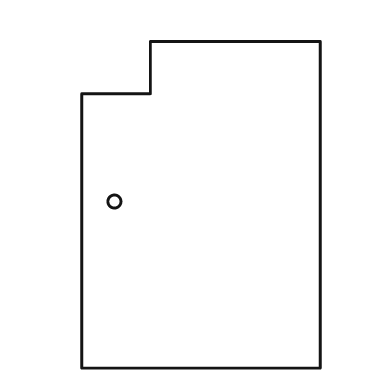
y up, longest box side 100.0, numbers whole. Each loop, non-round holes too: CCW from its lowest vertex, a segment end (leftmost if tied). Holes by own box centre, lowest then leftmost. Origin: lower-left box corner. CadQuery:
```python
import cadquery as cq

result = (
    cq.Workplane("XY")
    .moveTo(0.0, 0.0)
    .lineTo(73.0, 0.0)
    .lineTo(73.0, 100.0)
    .lineTo(21.0, 100.0)
    .lineTo(21.0, 84.0)
    .lineTo(0.0, 84.0)
    .close()
    .moveTo(10.0, 51.0)
    .circle(2.0)
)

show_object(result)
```